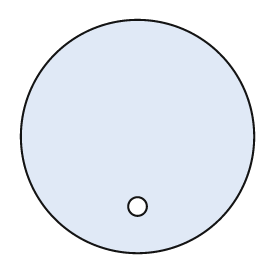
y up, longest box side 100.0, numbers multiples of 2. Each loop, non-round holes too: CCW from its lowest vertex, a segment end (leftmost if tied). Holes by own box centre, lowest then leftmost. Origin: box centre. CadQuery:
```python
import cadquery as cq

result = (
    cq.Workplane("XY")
    .moveTo(0.0, 0.0)
    .circle(50.0)
    .moveTo(0.0, -30.0)
    .circle(4.0)
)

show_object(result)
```